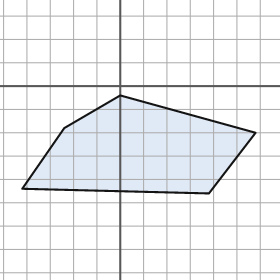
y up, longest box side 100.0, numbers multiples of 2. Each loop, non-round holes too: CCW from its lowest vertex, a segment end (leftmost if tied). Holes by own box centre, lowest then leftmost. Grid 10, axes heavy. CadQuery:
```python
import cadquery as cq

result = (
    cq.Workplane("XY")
    .moveTo(38.0, -46.0)
    .lineTo(58.0, -20.0)
    .lineTo(0.0, -4.0)
    .lineTo(-24.0, -18.0)
    .lineTo(-42.0, -44.0)
    .close()
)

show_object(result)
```